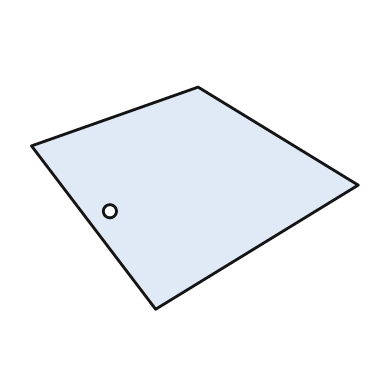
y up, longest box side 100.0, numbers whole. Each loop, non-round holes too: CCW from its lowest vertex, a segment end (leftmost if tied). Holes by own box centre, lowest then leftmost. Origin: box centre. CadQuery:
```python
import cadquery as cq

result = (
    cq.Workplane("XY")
    .moveTo(-12.0, -34.0)
    .lineTo(50.0, 4.0)
    .lineTo(1.0, 34.0)
    .lineTo(-50.0, 16.0)
    .close()
    .moveTo(-26.0, -4.0)
    .circle(2.0)
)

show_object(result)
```